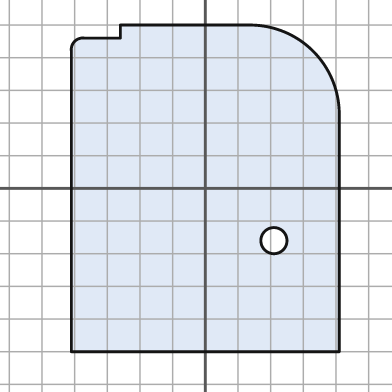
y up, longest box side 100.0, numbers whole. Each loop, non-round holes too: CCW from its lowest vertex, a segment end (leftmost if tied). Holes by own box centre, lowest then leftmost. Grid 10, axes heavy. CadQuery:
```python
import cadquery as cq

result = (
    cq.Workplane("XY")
    .moveTo(-41.0, -50.0)
    .lineTo(41.0, -50.0)
    .lineTo(41.0, 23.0)
    .threePointArc((33.0, 42.0), (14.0, 50.0))
    .lineTo(-26.0, 50.0)
    .lineTo(-26.0, 46.0)
    .lineTo(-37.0, 46.0)
    .threePointArc((-40.0, 45.0), (-41.0, 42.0))
    .close()
    .moveTo(21.0, -16.0)
    .circle(4.0)
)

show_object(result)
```